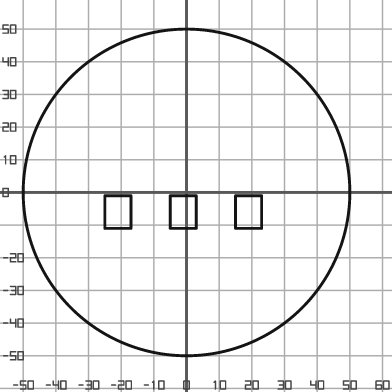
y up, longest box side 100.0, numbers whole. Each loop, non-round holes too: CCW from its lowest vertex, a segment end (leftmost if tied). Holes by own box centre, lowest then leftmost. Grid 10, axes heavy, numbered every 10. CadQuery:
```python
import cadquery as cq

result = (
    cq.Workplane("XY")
    .moveTo(0.0, 0.0)
    .circle(50.0)
    .moveTo(-25.0, -11.0)
    .lineTo(-17.0, -11.0)
    .lineTo(-17.0, -1.0)
    .lineTo(-25.0, -1.0)
    .close()
    .moveTo(-5.0, -11.0)
    .lineTo(3.0, -11.0)
    .lineTo(3.0, -1.0)
    .lineTo(-5.0, -1.0)
    .close()
    .moveTo(15.0, -11.0)
    .lineTo(23.0, -11.0)
    .lineTo(23.0, -1.0)
    .lineTo(15.0, -1.0)
    .close()
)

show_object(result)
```